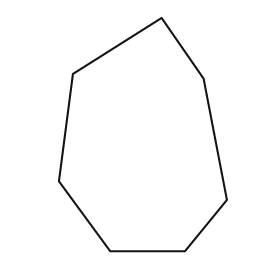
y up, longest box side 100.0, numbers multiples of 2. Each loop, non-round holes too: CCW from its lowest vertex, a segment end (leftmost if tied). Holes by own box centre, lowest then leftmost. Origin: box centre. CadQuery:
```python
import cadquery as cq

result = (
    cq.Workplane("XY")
    .moveTo(-14.0, -50.0)
    .lineTo(18.0, -50.0)
    .lineTo(36.0, -28.0)
    .lineTo(26.0, 24.0)
    .lineTo(8.0, 50.0)
    .lineTo(-30.0, 26.0)
    .lineTo(-36.0, -20.0)
    .close()
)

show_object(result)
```